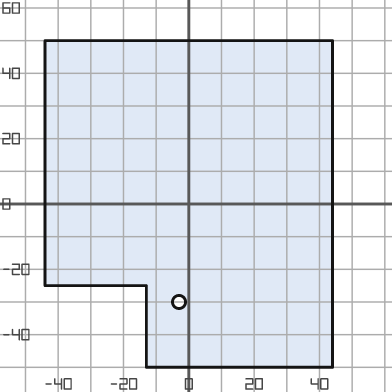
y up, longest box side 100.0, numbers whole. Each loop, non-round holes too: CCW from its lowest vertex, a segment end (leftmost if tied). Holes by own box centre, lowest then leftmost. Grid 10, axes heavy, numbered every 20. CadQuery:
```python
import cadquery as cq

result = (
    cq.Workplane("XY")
    .moveTo(-13.0, -50.0)
    .lineTo(44.0, -50.0)
    .lineTo(44.0, 50.0)
    .lineTo(-44.0, 50.0)
    .lineTo(-44.0, -25.0)
    .lineTo(-13.0, -25.0)
    .close()
    .moveTo(-3.0, -30.0)
    .circle(2.0)
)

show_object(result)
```